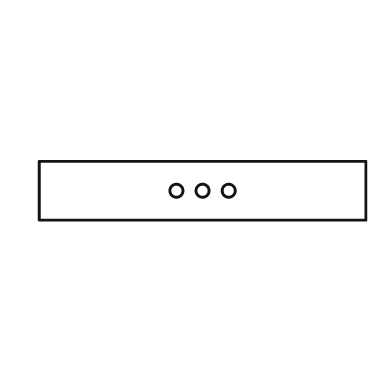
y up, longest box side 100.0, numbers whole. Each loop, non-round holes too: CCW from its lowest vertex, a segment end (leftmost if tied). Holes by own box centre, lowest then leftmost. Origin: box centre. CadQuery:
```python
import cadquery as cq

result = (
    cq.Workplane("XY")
    .moveTo(-50.0, -9.0)
    .lineTo(50.0, -9.0)
    .lineTo(50.0, 9.0)
    .lineTo(-50.0, 9.0)
    .close()
    .moveTo(-8.0, 0.0)
    .circle(2.0)
    .moveTo(0.0, 0.0)
    .circle(2.0)
    .moveTo(8.0, 0.0)
    .circle(2.0)
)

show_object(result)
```